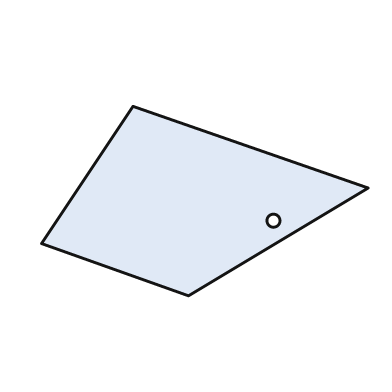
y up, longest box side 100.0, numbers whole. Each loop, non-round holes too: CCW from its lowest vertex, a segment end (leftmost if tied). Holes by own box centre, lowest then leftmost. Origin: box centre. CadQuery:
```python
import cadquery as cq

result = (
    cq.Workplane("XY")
    .moveTo(-5.0, -29.0)
    .lineTo(50.0, 4.0)
    .lineTo(-22.0, 29.0)
    .lineTo(-50.0, -13.0)
    .close()
    .moveTo(21.0, -6.0)
    .circle(2.0)
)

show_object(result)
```